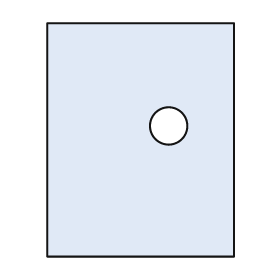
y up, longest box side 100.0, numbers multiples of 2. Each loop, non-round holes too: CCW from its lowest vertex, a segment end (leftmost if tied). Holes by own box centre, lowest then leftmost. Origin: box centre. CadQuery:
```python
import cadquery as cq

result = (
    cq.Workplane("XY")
    .moveTo(-40.0, -50.0)
    .lineTo(40.0, -50.0)
    .lineTo(40.0, 50.0)
    .lineTo(-40.0, 50.0)
    .close()
    .moveTo(12.0, 6.0)
    .circle(8.0)
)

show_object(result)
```